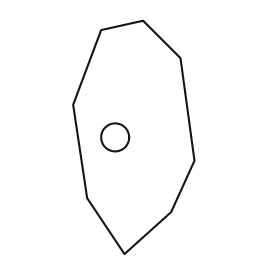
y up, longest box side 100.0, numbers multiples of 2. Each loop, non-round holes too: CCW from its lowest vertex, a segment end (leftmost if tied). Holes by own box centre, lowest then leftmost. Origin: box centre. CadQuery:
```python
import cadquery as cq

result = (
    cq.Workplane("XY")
    .moveTo(-4.0, -50.0)
    .lineTo(16.0, -32.0)
    .lineTo(26.0, -10.0)
    .lineTo(20.0, 34.0)
    .lineTo(4.0, 50.0)
    .lineTo(-14.0, 46.0)
    .lineTo(-26.0, 14.0)
    .lineTo(-20.0, -26.0)
    .close()
    .moveTo(-8.0, 0.0)
    .circle(6.0)
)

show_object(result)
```